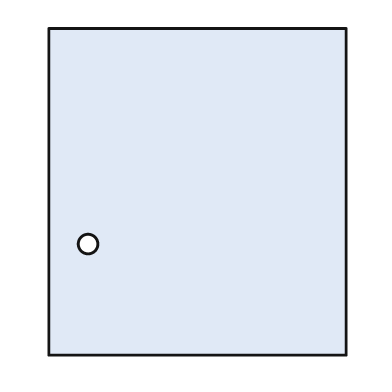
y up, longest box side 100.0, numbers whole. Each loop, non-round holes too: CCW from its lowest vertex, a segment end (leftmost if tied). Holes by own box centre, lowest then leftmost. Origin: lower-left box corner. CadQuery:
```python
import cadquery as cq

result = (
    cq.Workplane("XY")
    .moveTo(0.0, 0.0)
    .lineTo(91.0, 0.0)
    .lineTo(91.0, 100.0)
    .lineTo(0.0, 100.0)
    .close()
    .moveTo(12.0, 34.0)
    .circle(3.0)
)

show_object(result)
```